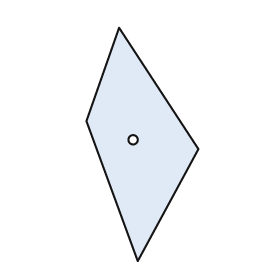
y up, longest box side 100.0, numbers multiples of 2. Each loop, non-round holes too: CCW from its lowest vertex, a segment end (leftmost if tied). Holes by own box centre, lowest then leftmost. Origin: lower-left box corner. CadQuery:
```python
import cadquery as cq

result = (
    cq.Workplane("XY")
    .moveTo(22.0, 0.0)
    .lineTo(48.0, 48.0)
    .lineTo(14.0, 100.0)
    .lineTo(0.0, 60.0)
    .close()
    .moveTo(20.0, 52.0)
    .circle(2.0)
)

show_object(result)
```